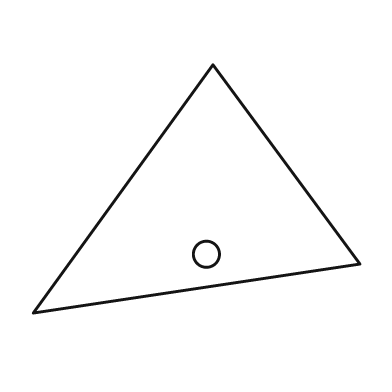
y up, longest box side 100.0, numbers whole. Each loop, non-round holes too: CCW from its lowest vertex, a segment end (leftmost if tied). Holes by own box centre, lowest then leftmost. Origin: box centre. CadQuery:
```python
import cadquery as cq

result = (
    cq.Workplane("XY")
    .moveTo(-50.0, -38.0)
    .lineTo(50.0, -23.0)
    .lineTo(5.0, 38.0)
    .close()
    .moveTo(3.0, -20.0)
    .circle(4.0)
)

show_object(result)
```